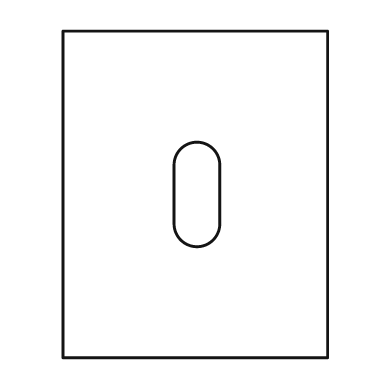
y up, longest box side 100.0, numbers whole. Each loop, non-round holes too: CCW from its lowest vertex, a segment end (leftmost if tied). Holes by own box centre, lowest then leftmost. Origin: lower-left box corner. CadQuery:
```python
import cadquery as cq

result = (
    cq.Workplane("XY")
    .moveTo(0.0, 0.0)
    .lineTo(81.0, 0.0)
    .lineTo(81.0, 100.0)
    .lineTo(0.0, 100.0)
    .close()
    .moveTo(34.0, 41.0)
    .threePointArc((41.0, 34.0), (48.0, 41.0))
    .lineTo(48.0, 59.0)
    .threePointArc((41.0, 66.0), (34.0, 59.0))
    .close()
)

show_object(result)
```